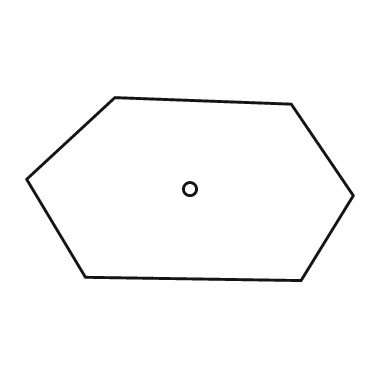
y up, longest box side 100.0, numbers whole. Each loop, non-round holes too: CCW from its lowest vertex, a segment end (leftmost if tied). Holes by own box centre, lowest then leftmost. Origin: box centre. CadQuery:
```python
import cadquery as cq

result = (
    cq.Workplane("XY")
    .moveTo(34.0, -28.0)
    .lineTo(50.0, -2.0)
    .lineTo(31.0, 26.0)
    .lineTo(-23.0, 28.0)
    .lineTo(-50.0, 3.0)
    .lineTo(-32.0, -27.0)
    .close()
    .moveTo(0.0, 0.0)
    .circle(2.0)
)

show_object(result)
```